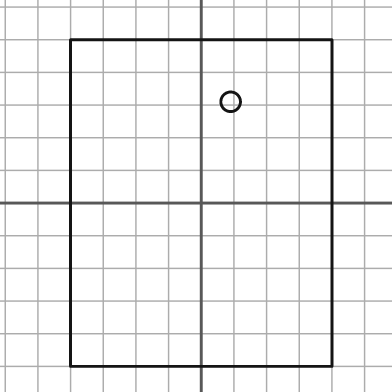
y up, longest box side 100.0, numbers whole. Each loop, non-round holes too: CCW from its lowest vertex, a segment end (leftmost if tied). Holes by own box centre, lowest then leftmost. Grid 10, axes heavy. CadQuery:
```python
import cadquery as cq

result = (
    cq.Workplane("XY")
    .moveTo(-40.0, -50.0)
    .lineTo(40.0, -50.0)
    .lineTo(40.0, 50.0)
    .lineTo(-40.0, 50.0)
    .close()
    .moveTo(9.0, 31.0)
    .circle(3.0)
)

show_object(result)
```